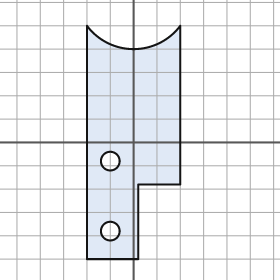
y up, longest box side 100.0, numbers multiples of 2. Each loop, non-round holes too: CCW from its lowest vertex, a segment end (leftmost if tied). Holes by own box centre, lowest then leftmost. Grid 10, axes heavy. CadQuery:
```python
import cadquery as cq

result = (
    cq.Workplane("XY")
    .moveTo(-20.0, -50.0)
    .lineTo(2.0, -50.0)
    .lineTo(2.0, -18.0)
    .lineTo(20.0, -18.0)
    .lineTo(20.0, 50.0)
    .threePointArc((0.0, 40.0), (-20.0, 50.0))
    .close()
    .moveTo(-10.0, -38.0)
    .circle(4.0)
    .moveTo(-10.0, -8.0)
    .circle(4.0)
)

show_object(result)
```